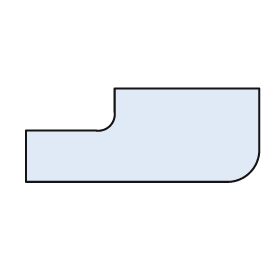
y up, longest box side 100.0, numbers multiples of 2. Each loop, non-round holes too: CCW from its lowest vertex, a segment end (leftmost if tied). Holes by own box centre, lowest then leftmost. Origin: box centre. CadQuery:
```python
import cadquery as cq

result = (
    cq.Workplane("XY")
    .moveTo(-50.0, -20.0)
    .lineTo(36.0, -20.0)
    .threePointArc((46.0, -16.0), (50.0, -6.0))
    .lineTo(50.0, 20.0)
    .lineTo(-12.0, 20.0)
    .lineTo(-12.0, 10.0)
    .threePointArc((-14.0, 4.0), (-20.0, 2.0))
    .lineTo(-50.0, 2.0)
    .close()
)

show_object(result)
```